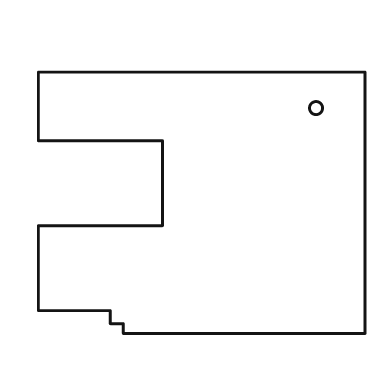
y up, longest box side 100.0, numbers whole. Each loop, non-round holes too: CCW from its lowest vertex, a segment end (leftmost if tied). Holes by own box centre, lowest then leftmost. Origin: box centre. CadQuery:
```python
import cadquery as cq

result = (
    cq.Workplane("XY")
    .moveTo(-24.0, -40.0)
    .lineTo(50.0, -40.0)
    .lineTo(50.0, 40.0)
    .lineTo(-50.0, 40.0)
    .lineTo(-50.0, 19.0)
    .lineTo(-12.0, 19.0)
    .lineTo(-12.0, -7.0)
    .lineTo(-50.0, -7.0)
    .lineTo(-50.0, -33.0)
    .lineTo(-28.0, -33.0)
    .lineTo(-28.0, -37.0)
    .lineTo(-24.0, -37.0)
    .close()
    .moveTo(35.0, 29.0)
    .circle(2.0)
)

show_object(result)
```